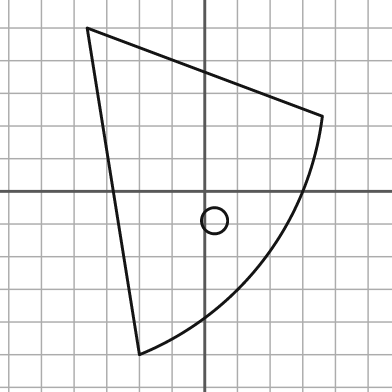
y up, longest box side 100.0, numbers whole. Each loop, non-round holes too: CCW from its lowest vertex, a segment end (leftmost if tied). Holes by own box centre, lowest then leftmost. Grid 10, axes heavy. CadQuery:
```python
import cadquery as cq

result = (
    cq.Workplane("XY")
    .moveTo(-20.0, -50.0)
    .threePointArc((18.0, -21.0), (36.0, 23.0))
    .lineTo(-36.0, 50.0)
    .close()
    .moveTo(3.0, -9.0)
    .circle(4.0)
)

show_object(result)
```